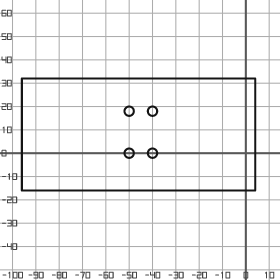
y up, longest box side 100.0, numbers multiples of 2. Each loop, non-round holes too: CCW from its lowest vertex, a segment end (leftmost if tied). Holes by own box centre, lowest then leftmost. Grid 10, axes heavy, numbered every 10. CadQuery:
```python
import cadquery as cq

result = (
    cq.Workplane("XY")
    .moveTo(-96.0, -16.0)
    .lineTo(4.0, -16.0)
    .lineTo(4.0, 32.0)
    .lineTo(-96.0, 32.0)
    .close()
    .moveTo(-50.0, 0.0)
    .circle(2.0)
    .moveTo(-40.0, 0.0)
    .circle(2.0)
    .moveTo(-50.0, 18.0)
    .circle(2.0)
    .moveTo(-40.0, 18.0)
    .circle(2.0)
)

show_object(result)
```